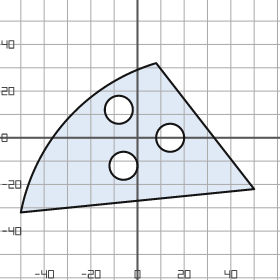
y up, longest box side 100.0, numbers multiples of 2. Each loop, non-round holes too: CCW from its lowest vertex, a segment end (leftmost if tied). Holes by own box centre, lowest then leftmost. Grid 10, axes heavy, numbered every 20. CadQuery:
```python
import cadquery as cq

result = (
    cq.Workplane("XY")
    .moveTo(-50.0, -32.0)
    .lineTo(50.0, -22.0)
    .lineTo(8.0, 32.0)
    .threePointArc((-30.0, 8.0), (-50.0, -32.0))
    .close()
    .moveTo(-6.0, -12.0)
    .circle(6.0)
    .moveTo(14.0, 0.0)
    .circle(6.0)
    .moveTo(-8.0, 12.0)
    .circle(6.0)
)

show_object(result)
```